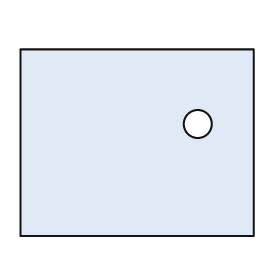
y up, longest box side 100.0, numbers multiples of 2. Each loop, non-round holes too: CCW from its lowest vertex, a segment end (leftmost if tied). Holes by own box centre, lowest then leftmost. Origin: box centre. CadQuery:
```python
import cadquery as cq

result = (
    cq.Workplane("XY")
    .moveTo(-50.0, -40.0)
    .lineTo(50.0, -40.0)
    .lineTo(50.0, 40.0)
    .lineTo(-50.0, 40.0)
    .close()
    .moveTo(26.0, 8.0)
    .circle(6.0)
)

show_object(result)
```